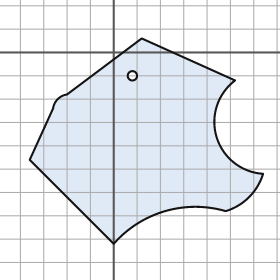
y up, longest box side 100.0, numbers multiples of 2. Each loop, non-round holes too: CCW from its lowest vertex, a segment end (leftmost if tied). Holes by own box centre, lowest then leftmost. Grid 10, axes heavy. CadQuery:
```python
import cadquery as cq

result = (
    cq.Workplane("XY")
    .moveTo(0.0, -82.0)
    .threePointArc((22.0, -68.0), (48.0, -68.0))
    .threePointArc((58.0, -62.0), (64.0, -52.0))
    .threePointArc((44.0, -36.0), (52.0, -12.0))
    .lineTo(12.0, 6.0)
    .lineTo(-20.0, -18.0)
    .threePointArc((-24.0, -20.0), (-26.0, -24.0))
    .lineTo(-36.0, -46.0)
    .close()
    .moveTo(8.0, -10.0)
    .circle(2.0)
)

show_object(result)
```